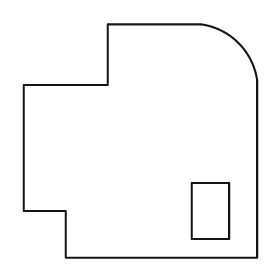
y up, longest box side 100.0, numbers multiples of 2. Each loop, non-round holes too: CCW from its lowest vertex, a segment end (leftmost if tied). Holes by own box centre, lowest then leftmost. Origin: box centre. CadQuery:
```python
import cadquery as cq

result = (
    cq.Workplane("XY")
    .moveTo(-32.0, -50.0)
    .lineTo(50.0, -50.0)
    .lineTo(50.0, 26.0)
    .threePointArc((42.0, 42.0), (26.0, 50.0))
    .lineTo(-14.0, 50.0)
    .lineTo(-14.0, 24.0)
    .lineTo(-50.0, 24.0)
    .lineTo(-50.0, -30.0)
    .lineTo(-32.0, -30.0)
    .close()
    .moveTo(22.0, -42.0)
    .lineTo(38.0, -42.0)
    .lineTo(38.0, -18.0)
    .lineTo(22.0, -18.0)
    .close()
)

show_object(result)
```